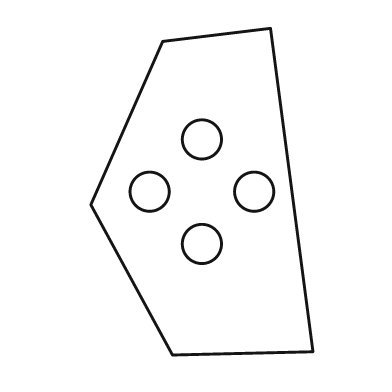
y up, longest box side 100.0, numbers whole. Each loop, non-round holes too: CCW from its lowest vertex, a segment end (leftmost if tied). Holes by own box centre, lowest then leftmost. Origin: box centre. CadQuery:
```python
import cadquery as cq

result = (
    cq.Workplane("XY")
    .moveTo(-9.0, -50.0)
    .lineTo(34.0, -49.0)
    .lineTo(21.0, 50.0)
    .lineTo(-12.0, 46.0)
    .lineTo(-34.0, -4.0)
    .close()
    .moveTo(0.0, -16.0)
    .circle(6.0)
    .moveTo(-16.0, 0.0)
    .circle(6.0)
    .moveTo(16.0, 0.0)
    .circle(6.0)
    .moveTo(0.0, 16.0)
    .circle(6.0)
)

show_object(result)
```